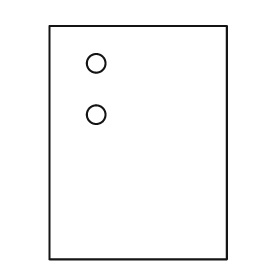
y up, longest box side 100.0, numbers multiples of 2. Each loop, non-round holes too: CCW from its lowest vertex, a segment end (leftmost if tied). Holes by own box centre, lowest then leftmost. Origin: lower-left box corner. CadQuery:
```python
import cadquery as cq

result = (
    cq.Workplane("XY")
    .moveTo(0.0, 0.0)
    .lineTo(76.0, 0.0)
    .lineTo(76.0, 100.0)
    .lineTo(0.0, 100.0)
    .close()
    .moveTo(20.0, 62.0)
    .circle(4.0)
    .moveTo(20.0, 84.0)
    .circle(4.0)
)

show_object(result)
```